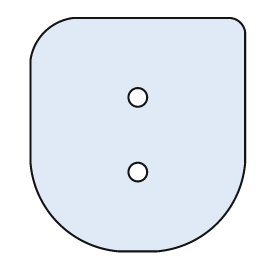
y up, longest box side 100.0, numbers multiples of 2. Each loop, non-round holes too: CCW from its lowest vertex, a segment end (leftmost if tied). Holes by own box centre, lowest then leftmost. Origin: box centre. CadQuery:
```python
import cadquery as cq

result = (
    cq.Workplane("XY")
    .moveTo(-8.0, -50.0)
    .lineTo(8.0, -50.0)
    .threePointArc((34.0, -38.0), (46.0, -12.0))
    .lineTo(46.0, 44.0)
    .threePointArc((44.0, 48.0), (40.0, 50.0))
    .lineTo(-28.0, 50.0)
    .threePointArc((-40.0, 44.0), (-46.0, 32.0))
    .lineTo(-46.0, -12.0)
    .threePointArc((-34.0, -38.0), (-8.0, -50.0))
    .close()
    .moveTo(0.0, -16.0)
    .circle(4.0)
    .moveTo(0.0, 16.0)
    .circle(4.0)
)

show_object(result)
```